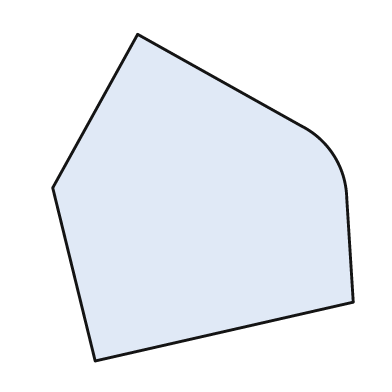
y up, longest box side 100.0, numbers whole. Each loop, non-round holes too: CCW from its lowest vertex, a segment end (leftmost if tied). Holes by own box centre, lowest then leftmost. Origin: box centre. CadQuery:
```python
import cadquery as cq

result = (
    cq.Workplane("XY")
    .moveTo(-33.0, -50.0)
    .lineTo(46.0, -32.0)
    .lineTo(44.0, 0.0)
    .threePointArc((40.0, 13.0), (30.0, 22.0))
    .lineTo(-20.0, 50.0)
    .lineTo(-46.0, 3.0)
    .close()
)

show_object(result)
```